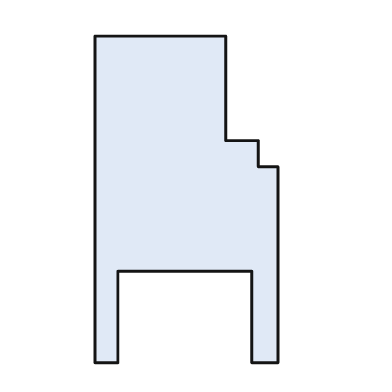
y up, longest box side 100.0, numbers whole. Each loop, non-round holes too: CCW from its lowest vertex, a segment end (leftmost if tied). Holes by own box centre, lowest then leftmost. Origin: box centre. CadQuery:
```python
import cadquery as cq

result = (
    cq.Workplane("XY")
    .moveTo(-28.0, -50.0)
    .lineTo(-21.0, -50.0)
    .lineTo(-21.0, -22.0)
    .lineTo(20.0, -22.0)
    .lineTo(20.0, -50.0)
    .lineTo(28.0, -50.0)
    .lineTo(28.0, 10.0)
    .lineTo(22.0, 10.0)
    .lineTo(22.0, 18.0)
    .lineTo(12.0, 18.0)
    .lineTo(12.0, 50.0)
    .lineTo(-28.0, 50.0)
    .close()
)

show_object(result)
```